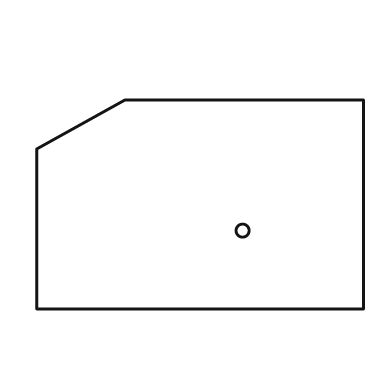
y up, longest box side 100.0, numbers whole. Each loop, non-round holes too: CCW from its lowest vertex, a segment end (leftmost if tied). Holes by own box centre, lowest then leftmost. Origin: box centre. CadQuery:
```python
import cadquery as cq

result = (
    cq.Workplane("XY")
    .moveTo(-50.0, -32.0)
    .lineTo(50.0, -32.0)
    .lineTo(50.0, 32.0)
    .lineTo(-23.0, 32.0)
    .lineTo(-50.0, 17.0)
    .close()
    .moveTo(13.0, -8.0)
    .circle(2.0)
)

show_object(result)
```